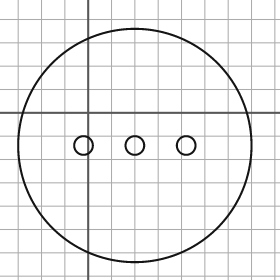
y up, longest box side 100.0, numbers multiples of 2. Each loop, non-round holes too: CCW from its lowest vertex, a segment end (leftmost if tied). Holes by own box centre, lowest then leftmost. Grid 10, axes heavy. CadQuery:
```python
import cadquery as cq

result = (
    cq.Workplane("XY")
    .moveTo(20.0, -14.0)
    .circle(50.0)
    .moveTo(-2.0, -14.0)
    .circle(4.0)
    .moveTo(20.0, -14.0)
    .circle(4.0)
    .moveTo(42.0, -14.0)
    .circle(4.0)
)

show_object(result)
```